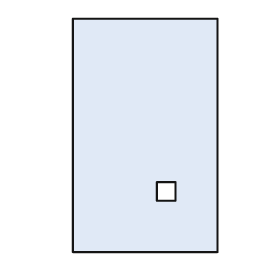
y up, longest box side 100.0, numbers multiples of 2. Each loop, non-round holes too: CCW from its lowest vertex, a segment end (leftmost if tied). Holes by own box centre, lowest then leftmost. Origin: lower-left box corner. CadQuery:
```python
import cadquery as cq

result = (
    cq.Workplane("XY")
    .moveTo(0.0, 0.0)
    .lineTo(62.0, 0.0)
    .lineTo(62.0, 100.0)
    .lineTo(0.0, 100.0)
    .close()
    .moveTo(36.0, 22.0)
    .lineTo(44.0, 22.0)
    .lineTo(44.0, 30.0)
    .lineTo(36.0, 30.0)
    .close()
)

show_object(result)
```